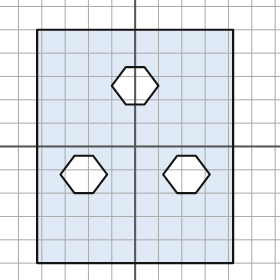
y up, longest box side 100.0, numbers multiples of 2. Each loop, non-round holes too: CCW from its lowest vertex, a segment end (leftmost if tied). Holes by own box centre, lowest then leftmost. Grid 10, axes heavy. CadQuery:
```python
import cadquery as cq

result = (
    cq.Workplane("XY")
    .moveTo(-42.0, -50.0)
    .lineTo(42.0, -50.0)
    .lineTo(42.0, 50.0)
    .lineTo(-42.0, 50.0)
    .close()
    .moveTo(-26.0, -20.0)
    .lineTo(-18.0, -20.0)
    .lineTo(-12.0, -12.0)
    .lineTo(-18.0, -4.0)
    .lineTo(-26.0, -4.0)
    .lineTo(-32.0, -12.0)
    .close()
    .moveTo(18.0, -20.0)
    .lineTo(26.0, -20.0)
    .lineTo(32.0, -12.0)
    .lineTo(26.0, -4.0)
    .lineTo(18.0, -4.0)
    .lineTo(12.0, -12.0)
    .close()
    .moveTo(-4.0, 18.0)
    .lineTo(4.0, 18.0)
    .lineTo(10.0, 26.0)
    .lineTo(4.0, 34.0)
    .lineTo(-4.0, 34.0)
    .lineTo(-10.0, 26.0)
    .close()
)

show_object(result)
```